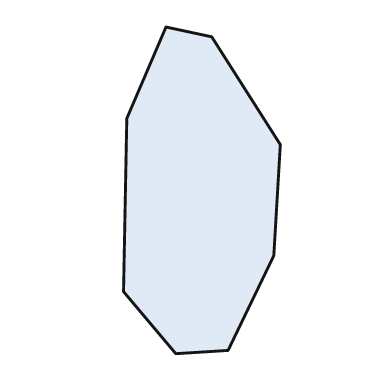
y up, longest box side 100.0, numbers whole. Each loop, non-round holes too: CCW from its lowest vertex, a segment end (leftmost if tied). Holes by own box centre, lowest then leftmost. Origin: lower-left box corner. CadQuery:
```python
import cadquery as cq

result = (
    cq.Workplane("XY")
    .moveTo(16.0, 0.0)
    .lineTo(32.0, 1.0)
    .lineTo(46.0, 30.0)
    .lineTo(48.0, 64.0)
    .lineTo(27.0, 97.0)
    .lineTo(13.0, 100.0)
    .lineTo(1.0, 72.0)
    .lineTo(0.0, 19.0)
    .close()
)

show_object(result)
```